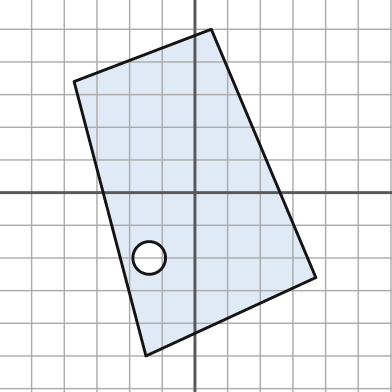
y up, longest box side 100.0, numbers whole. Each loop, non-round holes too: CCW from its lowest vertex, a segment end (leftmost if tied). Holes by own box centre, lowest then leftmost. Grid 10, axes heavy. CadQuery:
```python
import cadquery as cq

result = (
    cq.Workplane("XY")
    .moveTo(-15.0, -50.0)
    .lineTo(37.0, -26.0)
    .lineTo(5.0, 50.0)
    .lineTo(-37.0, 34.0)
    .close()
    .moveTo(-14.0, -20.0)
    .circle(5.0)
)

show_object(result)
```